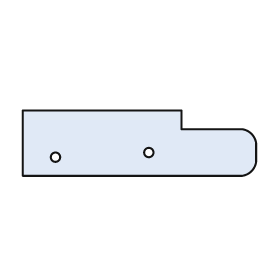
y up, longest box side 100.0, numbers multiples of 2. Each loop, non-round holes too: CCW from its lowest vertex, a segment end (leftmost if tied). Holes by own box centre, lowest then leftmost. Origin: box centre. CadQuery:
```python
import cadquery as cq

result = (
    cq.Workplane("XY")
    .moveTo(-50.0, -14.0)
    .lineTo(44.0, -14.0)
    .threePointArc((48.0, -12.0), (50.0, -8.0))
    .lineTo(50.0, 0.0)
    .threePointArc((48.0, 4.0), (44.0, 6.0))
    .lineTo(18.0, 6.0)
    .lineTo(18.0, 14.0)
    .lineTo(-50.0, 14.0)
    .close()
    .moveTo(-36.0, -6.0)
    .circle(2.0)
    .moveTo(4.0, -4.0)
    .circle(2.0)
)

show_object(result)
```